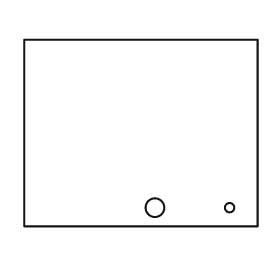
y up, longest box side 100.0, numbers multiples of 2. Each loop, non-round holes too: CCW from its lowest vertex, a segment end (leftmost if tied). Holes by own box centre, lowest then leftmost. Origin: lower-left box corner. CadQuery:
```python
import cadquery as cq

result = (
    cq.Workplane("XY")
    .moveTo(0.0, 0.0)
    .lineTo(100.0, 0.0)
    .lineTo(100.0, 80.0)
    .lineTo(0.0, 80.0)
    .close()
    .moveTo(56.0, 8.0)
    .circle(4.0)
    .moveTo(88.0, 8.0)
    .circle(2.0)
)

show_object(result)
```